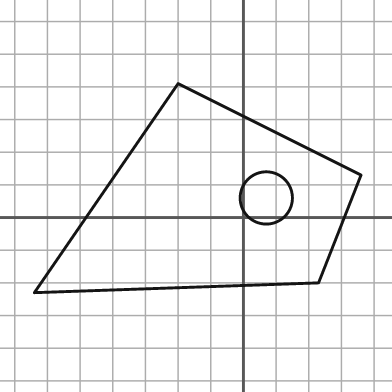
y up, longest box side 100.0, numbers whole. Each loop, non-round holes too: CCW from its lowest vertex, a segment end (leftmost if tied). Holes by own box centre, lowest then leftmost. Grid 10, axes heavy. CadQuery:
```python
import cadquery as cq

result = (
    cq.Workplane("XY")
    .moveTo(-64.0, -23.0)
    .lineTo(23.0, -20.0)
    .lineTo(36.0, 13.0)
    .lineTo(-20.0, 41.0)
    .close()
    .moveTo(7.0, 6.0)
    .circle(8.0)
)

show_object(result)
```